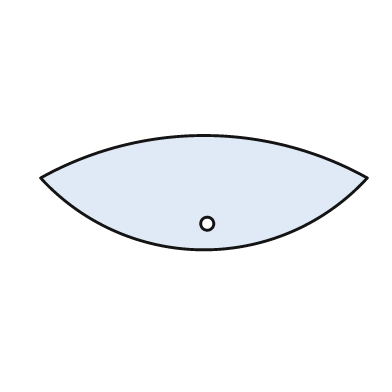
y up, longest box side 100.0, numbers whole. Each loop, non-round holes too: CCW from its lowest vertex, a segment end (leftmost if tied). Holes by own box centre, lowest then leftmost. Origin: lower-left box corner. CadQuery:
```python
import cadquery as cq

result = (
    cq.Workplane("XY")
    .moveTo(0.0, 22.0)
    .threePointArc((50.0, 0.0), (100.0, 22.0))
    .threePointArc((50.0, 35.0), (0.0, 22.0))
    .close()
    .moveTo(51.0, 8.0)
    .circle(2.0)
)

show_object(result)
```